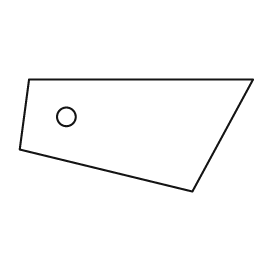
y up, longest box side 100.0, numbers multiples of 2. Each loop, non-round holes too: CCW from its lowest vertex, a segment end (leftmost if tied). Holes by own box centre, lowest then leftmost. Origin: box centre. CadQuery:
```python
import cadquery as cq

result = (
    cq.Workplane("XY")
    .moveTo(24.0, -24.0)
    .lineTo(50.0, 24.0)
    .lineTo(-46.0, 24.0)
    .lineTo(-50.0, -6.0)
    .close()
    .moveTo(-30.0, 8.0)
    .circle(4.0)
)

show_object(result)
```